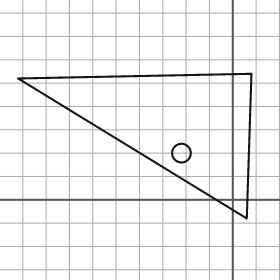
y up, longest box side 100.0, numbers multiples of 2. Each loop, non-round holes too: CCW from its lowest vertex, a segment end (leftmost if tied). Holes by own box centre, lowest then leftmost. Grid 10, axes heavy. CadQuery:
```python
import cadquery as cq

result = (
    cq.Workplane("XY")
    .moveTo(6.0, -8.0)
    .lineTo(8.0, 54.0)
    .lineTo(-92.0, 52.0)
    .close()
    .moveTo(-22.0, 20.0)
    .circle(4.0)
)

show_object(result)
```